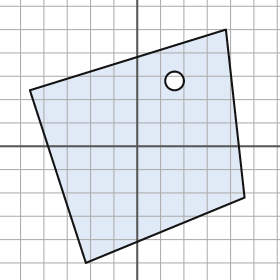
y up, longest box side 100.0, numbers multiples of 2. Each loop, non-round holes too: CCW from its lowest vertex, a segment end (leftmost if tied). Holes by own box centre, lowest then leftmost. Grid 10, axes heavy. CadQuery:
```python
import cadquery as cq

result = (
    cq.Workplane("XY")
    .moveTo(-22.0, -50.0)
    .lineTo(46.0, -22.0)
    .lineTo(38.0, 50.0)
    .lineTo(-46.0, 24.0)
    .close()
    .moveTo(16.0, 28.0)
    .circle(4.0)
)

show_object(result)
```